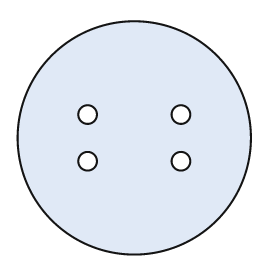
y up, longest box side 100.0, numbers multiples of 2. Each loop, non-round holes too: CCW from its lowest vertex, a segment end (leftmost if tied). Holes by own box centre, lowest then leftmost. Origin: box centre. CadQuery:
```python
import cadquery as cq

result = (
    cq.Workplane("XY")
    .moveTo(0.0, 0.0)
    .circle(50.0)
    .moveTo(-20.0, -10.0)
    .circle(4.0)
    .moveTo(20.0, -10.0)
    .circle(4.0)
    .moveTo(-20.0, 10.0)
    .circle(4.0)
    .moveTo(20.0, 10.0)
    .circle(4.0)
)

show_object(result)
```